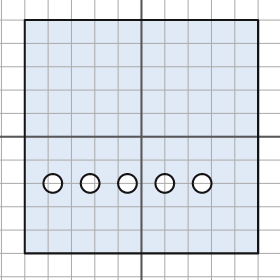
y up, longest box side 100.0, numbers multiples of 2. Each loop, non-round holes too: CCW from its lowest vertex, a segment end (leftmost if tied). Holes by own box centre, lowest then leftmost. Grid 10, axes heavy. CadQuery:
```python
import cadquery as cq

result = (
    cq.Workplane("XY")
    .moveTo(-50.0, -50.0)
    .lineTo(50.0, -50.0)
    .lineTo(50.0, 50.0)
    .lineTo(-50.0, 50.0)
    .close()
    .moveTo(-38.0, -20.0)
    .circle(4.0)
    .moveTo(-22.0, -20.0)
    .circle(4.0)
    .moveTo(-6.0, -20.0)
    .circle(4.0)
    .moveTo(10.0, -20.0)
    .circle(4.0)
    .moveTo(26.0, -20.0)
    .circle(4.0)
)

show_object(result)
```